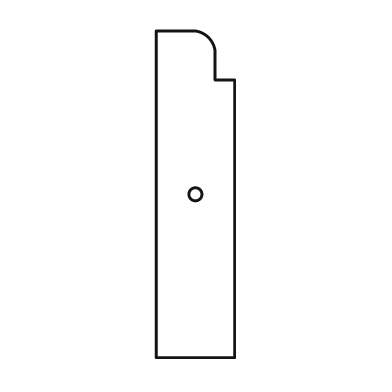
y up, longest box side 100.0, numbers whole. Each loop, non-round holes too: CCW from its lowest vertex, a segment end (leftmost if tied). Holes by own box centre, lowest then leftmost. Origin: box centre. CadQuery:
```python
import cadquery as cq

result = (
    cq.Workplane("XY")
    .moveTo(-12.0, -50.0)
    .lineTo(12.0, -50.0)
    .lineTo(12.0, 35.0)
    .lineTo(6.0, 35.0)
    .lineTo(6.0, 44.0)
    .threePointArc((4.0, 48.0), (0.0, 50.0))
    .lineTo(-12.0, 50.0)
    .close()
    .moveTo(0.0, 0.0)
    .circle(2.0)
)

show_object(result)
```